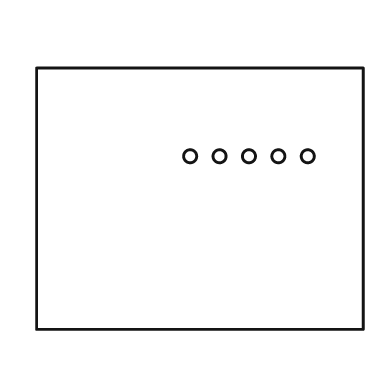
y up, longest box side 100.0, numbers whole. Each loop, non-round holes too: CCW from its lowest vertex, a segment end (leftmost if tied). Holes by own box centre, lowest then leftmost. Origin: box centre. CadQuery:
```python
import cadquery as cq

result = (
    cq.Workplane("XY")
    .moveTo(-50.0, -40.0)
    .lineTo(50.0, -40.0)
    .lineTo(50.0, 40.0)
    .lineTo(-50.0, 40.0)
    .close()
    .moveTo(-3.0, 13.0)
    .circle(2.0)
    .moveTo(6.0, 13.0)
    .circle(2.0)
    .moveTo(15.0, 13.0)
    .circle(2.0)
    .moveTo(24.0, 13.0)
    .circle(2.0)
    .moveTo(33.0, 13.0)
    .circle(2.0)
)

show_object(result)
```